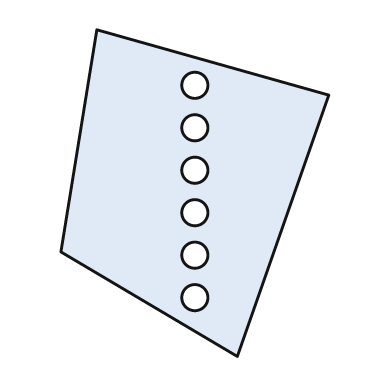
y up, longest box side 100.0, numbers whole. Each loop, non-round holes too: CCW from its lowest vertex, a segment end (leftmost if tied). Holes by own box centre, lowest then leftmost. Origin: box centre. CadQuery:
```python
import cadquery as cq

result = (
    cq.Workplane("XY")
    .moveTo(13.0, -50.0)
    .lineTo(41.0, 30.0)
    .lineTo(-30.0, 50.0)
    .lineTo(-41.0, -18.0)
    .close()
    .moveTo(0.0, -32.0)
    .circle(4.0)
    .moveTo(0.0, -19.0)
    .circle(4.0)
    .moveTo(0.0, -6.0)
    .circle(4.0)
    .moveTo(0.0, 7.0)
    .circle(4.0)
    .moveTo(0.0, 20.0)
    .circle(4.0)
    .moveTo(0.0, 33.0)
    .circle(4.0)
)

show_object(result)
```